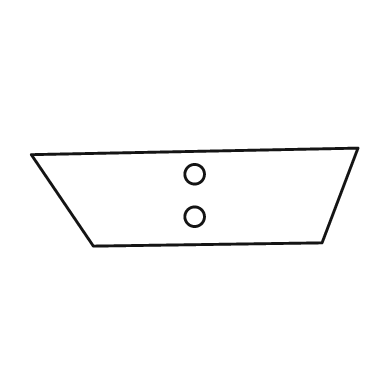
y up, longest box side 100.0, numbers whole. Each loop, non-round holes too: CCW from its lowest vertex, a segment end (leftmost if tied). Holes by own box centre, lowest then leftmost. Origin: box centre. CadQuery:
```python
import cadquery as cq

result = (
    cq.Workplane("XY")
    .moveTo(-31.0, -15.0)
    .lineTo(39.0, -14.0)
    .lineTo(50.0, 15.0)
    .lineTo(-50.0, 13.0)
    .close()
    .moveTo(0.0, -6.0)
    .circle(3.0)
    .moveTo(0.0, 7.0)
    .circle(3.0)
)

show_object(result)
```